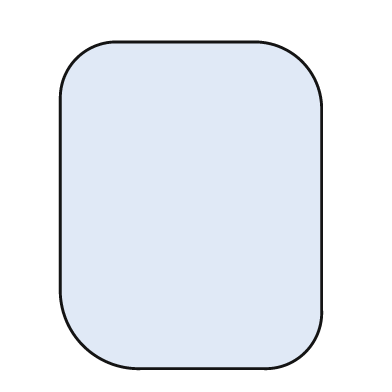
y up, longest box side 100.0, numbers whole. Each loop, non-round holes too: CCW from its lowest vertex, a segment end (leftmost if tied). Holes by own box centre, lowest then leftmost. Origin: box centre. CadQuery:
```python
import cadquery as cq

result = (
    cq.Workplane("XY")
    .moveTo(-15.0, -50.0)
    .lineTo(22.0, -50.0)
    .threePointArc((35.0, -45.0), (40.0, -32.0))
    .lineTo(40.0, 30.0)
    .threePointArc((34.0, 44.0), (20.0, 50.0))
    .lineTo(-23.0, 50.0)
    .threePointArc((-35.0, 45.0), (-40.0, 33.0))
    .lineTo(-40.0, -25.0)
    .threePointArc((-33.0, -43.0), (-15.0, -50.0))
    .close()
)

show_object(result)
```